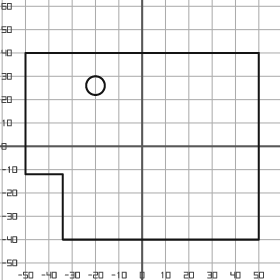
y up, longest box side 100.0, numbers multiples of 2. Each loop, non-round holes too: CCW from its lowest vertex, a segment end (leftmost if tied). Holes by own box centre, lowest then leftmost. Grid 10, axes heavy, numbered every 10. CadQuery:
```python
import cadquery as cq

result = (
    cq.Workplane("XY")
    .moveTo(-34.0, -40.0)
    .lineTo(50.0, -40.0)
    .lineTo(50.0, 40.0)
    .lineTo(-50.0, 40.0)
    .lineTo(-50.0, -12.0)
    .lineTo(-34.0, -12.0)
    .close()
    .moveTo(-20.0, 26.0)
    .circle(4.0)
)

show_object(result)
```